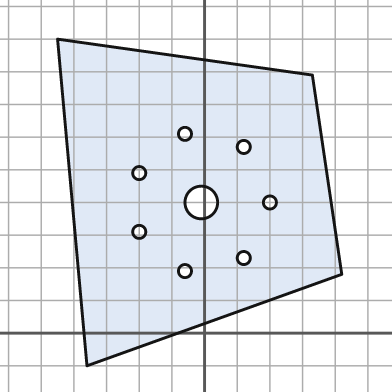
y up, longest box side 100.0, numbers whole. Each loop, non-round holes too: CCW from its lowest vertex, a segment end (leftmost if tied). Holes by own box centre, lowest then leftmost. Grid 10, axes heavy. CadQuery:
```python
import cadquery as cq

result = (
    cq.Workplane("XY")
    .moveTo(-36.0, -10.0)
    .lineTo(42.0, 18.0)
    .lineTo(33.0, 79.0)
    .lineTo(-45.0, 90.0)
    .close()
    .moveTo(-6.0, 19.0)
    .circle(2.0)
    .moveTo(12.0, 23.0)
    .circle(2.0)
    .moveTo(-20.0, 31.0)
    .circle(2.0)
    .moveTo(-1.0, 40.0)
    .circle(5.0)
    .moveTo(20.0, 40.0)
    .circle(2.0)
    .moveTo(-20.0, 49.0)
    .circle(2.0)
    .moveTo(12.0, 57.0)
    .circle(2.0)
    .moveTo(-6.0, 61.0)
    .circle(2.0)
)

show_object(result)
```